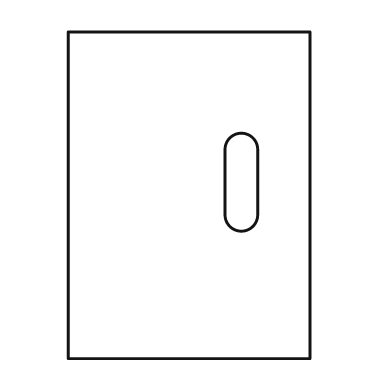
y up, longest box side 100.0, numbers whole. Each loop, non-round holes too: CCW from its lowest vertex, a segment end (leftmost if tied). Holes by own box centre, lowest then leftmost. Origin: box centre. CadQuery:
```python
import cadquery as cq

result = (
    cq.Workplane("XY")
    .moveTo(-37.0, -50.0)
    .lineTo(37.0, -50.0)
    .lineTo(37.0, 50.0)
    .lineTo(-37.0, 50.0)
    .close()
    .moveTo(11.0, -6.0)
    .threePointArc((16.0, -11.0), (21.0, -6.0))
    .lineTo(21.0, 14.0)
    .threePointArc((16.0, 19.0), (11.0, 14.0))
    .close()
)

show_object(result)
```